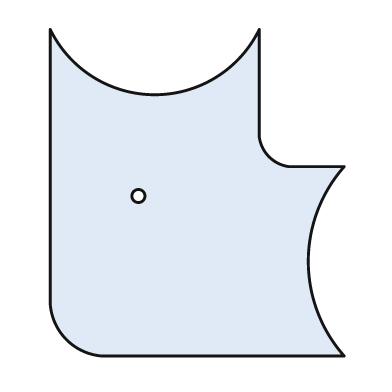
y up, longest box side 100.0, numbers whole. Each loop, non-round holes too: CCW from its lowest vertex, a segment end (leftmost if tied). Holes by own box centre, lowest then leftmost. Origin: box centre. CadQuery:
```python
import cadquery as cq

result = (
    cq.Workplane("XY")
    .moveTo(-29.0, -50.0)
    .lineTo(45.0, -50.0)
    .threePointArc((34.0, -21.0), (45.0, 8.0))
    .lineTo(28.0, 8.0)
    .threePointArc((22.0, 11.0), (19.0, 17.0))
    .lineTo(19.0, 50.0)
    .threePointArc((-13.0, 30.0), (-45.0, 50.0))
    .lineTo(-45.0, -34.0)
    .threePointArc((-40.0, -45.0), (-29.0, -50.0))
    .close()
    .moveTo(-18.0, -1.0)
    .circle(2.0)
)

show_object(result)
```